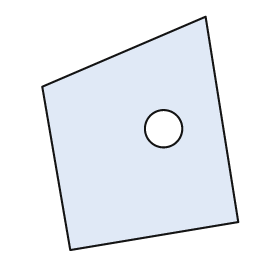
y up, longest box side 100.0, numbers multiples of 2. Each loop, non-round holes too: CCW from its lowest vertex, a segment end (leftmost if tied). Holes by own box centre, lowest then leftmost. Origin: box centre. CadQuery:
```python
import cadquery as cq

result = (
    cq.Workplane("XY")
    .moveTo(-30.0, -50.0)
    .lineTo(42.0, -38.0)
    .lineTo(28.0, 50.0)
    .lineTo(-42.0, 20.0)
    .close()
    .moveTo(10.0, 2.0)
    .circle(8.0)
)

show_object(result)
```